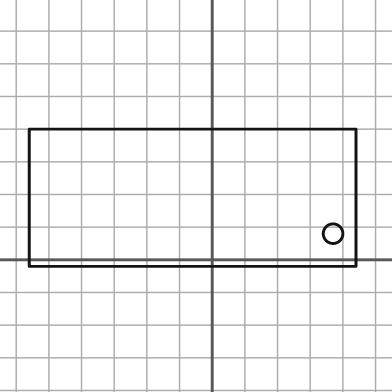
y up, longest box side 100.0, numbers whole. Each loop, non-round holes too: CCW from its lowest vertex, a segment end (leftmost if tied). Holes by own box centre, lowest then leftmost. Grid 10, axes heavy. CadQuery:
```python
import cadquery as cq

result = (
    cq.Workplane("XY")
    .moveTo(-56.0, -2.0)
    .lineTo(44.0, -2.0)
    .lineTo(44.0, 40.0)
    .lineTo(-56.0, 40.0)
    .close()
    .moveTo(37.0, 8.0)
    .circle(3.0)
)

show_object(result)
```